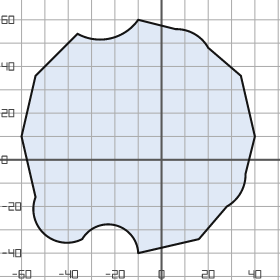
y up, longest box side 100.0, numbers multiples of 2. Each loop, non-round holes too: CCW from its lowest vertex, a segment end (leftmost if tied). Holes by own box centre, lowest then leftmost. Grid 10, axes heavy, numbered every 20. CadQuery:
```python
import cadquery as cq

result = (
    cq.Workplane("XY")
    .moveTo(-10.0, -40.0)
    .lineTo(16.0, -34.0)
    .lineTo(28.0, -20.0)
    .threePointArc((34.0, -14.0), (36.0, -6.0))
    .lineTo(40.0, 10.0)
    .lineTo(34.0, 36.0)
    .lineTo(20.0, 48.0)
    .threePointArc((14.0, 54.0), (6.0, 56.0))
    .lineTo(-10.0, 60.0)
    .threePointArc((-22.0, 52.0), (-36.0, 54.0))
    .lineTo(-54.0, 36.0)
    .lineTo(-60.0, 10.0)
    .lineTo(-54.0, -16.0)
    .threePointArc((-50.0, -32.0), (-34.0, -34.0))
    .threePointArc((-20.0, -28.0), (-10.0, -40.0))
    .close()
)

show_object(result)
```